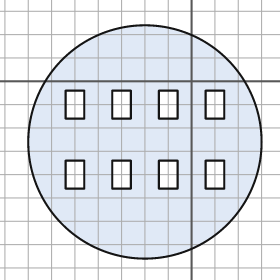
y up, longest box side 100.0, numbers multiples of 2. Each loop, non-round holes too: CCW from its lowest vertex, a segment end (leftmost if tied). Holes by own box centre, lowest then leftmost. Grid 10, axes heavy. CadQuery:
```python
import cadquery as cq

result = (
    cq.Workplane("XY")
    .moveTo(-20.0, -26.0)
    .circle(50.0)
    .moveTo(-54.0, -46.0)
    .lineTo(-46.0, -46.0)
    .lineTo(-46.0, -34.0)
    .lineTo(-54.0, -34.0)
    .close()
    .moveTo(-34.0, -46.0)
    .lineTo(-26.0, -46.0)
    .lineTo(-26.0, -34.0)
    .lineTo(-34.0, -34.0)
    .close()
    .moveTo(-14.0, -46.0)
    .lineTo(-6.0, -46.0)
    .lineTo(-6.0, -34.0)
    .lineTo(-14.0, -34.0)
    .close()
    .moveTo(6.0, -46.0)
    .lineTo(14.0, -46.0)
    .lineTo(14.0, -34.0)
    .lineTo(6.0, -34.0)
    .close()
    .moveTo(-54.0, -16.0)
    .lineTo(-46.0, -16.0)
    .lineTo(-46.0, -4.0)
    .lineTo(-54.0, -4.0)
    .close()
    .moveTo(-34.0, -16.0)
    .lineTo(-26.0, -16.0)
    .lineTo(-26.0, -4.0)
    .lineTo(-34.0, -4.0)
    .close()
    .moveTo(-14.0, -16.0)
    .lineTo(-6.0, -16.0)
    .lineTo(-6.0, -4.0)
    .lineTo(-14.0, -4.0)
    .close()
    .moveTo(6.0, -16.0)
    .lineTo(14.0, -16.0)
    .lineTo(14.0, -4.0)
    .lineTo(6.0, -4.0)
    .close()
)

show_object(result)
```